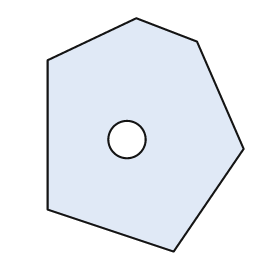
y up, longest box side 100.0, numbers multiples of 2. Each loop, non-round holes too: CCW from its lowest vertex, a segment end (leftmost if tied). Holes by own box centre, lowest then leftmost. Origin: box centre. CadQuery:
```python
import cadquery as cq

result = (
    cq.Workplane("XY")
    .moveTo(12.0, -50.0)
    .lineTo(42.0, -6.0)
    .lineTo(22.0, 40.0)
    .lineTo(-4.0, 50.0)
    .lineTo(-42.0, 32.0)
    .lineTo(-42.0, -32.0)
    .close()
    .moveTo(-8.0, -2.0)
    .circle(8.0)
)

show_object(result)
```